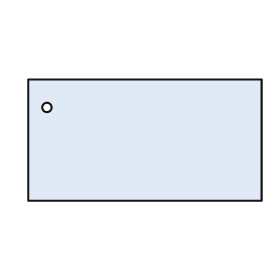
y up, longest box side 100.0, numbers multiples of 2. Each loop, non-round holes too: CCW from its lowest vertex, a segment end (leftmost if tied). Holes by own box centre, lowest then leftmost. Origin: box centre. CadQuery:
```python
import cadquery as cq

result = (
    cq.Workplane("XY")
    .moveTo(-50.0, -26.0)
    .lineTo(50.0, -26.0)
    .lineTo(50.0, 26.0)
    .lineTo(-50.0, 26.0)
    .close()
    .moveTo(-42.0, 14.0)
    .circle(2.0)
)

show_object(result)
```